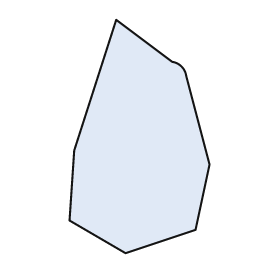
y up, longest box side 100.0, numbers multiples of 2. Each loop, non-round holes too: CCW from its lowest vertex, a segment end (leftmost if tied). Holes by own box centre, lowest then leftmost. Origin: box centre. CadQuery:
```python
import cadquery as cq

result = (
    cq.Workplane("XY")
    .moveTo(-6.0, -50.0)
    .lineTo(24.0, -40.0)
    .lineTo(30.0, -12.0)
    .lineTo(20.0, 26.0)
    .threePointArc((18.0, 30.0), (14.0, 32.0))
    .lineTo(-10.0, 50.0)
    .lineTo(-28.0, -6.0)
    .lineTo(-30.0, -36.0)
    .close()
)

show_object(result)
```